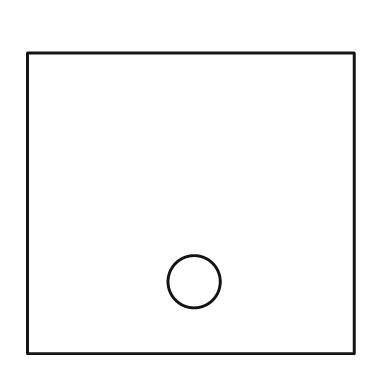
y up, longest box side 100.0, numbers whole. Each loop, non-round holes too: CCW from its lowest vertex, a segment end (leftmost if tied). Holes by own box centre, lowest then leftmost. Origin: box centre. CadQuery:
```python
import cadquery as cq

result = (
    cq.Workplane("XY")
    .moveTo(-50.0, -46.0)
    .lineTo(50.0, -46.0)
    .lineTo(50.0, 46.0)
    .lineTo(-50.0, 46.0)
    .close()
    .moveTo(1.0, -24.0)
    .circle(8.0)
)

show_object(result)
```